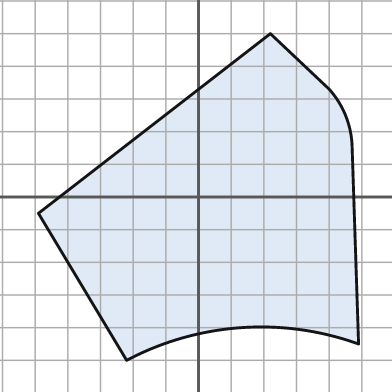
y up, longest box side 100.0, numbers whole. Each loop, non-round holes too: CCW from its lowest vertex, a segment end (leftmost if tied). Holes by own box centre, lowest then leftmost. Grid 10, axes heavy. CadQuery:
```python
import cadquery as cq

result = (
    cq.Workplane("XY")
    .moveTo(-22.0, -50.0)
    .threePointArc((13.0, -40.0), (49.0, -45.0))
    .lineTo(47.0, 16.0)
    .threePointArc((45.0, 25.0), (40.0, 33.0))
    .lineTo(22.0, 50.0)
    .lineTo(-49.0, -5.0)
    .close()
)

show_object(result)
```